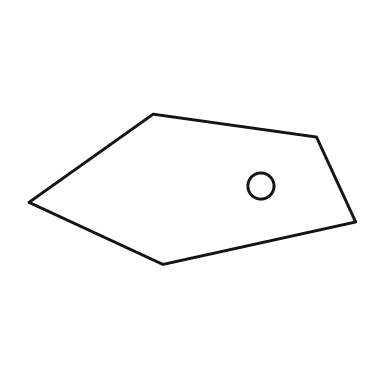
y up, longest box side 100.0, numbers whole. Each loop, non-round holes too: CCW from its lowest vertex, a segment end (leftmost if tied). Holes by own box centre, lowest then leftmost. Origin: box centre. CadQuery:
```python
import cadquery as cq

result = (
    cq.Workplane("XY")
    .moveTo(-9.0, -23.0)
    .lineTo(50.0, -10.0)
    .lineTo(38.0, 16.0)
    .lineTo(-12.0, 23.0)
    .lineTo(-50.0, -4.0)
    .close()
    .moveTo(21.0, 1.0)
    .circle(4.0)
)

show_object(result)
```